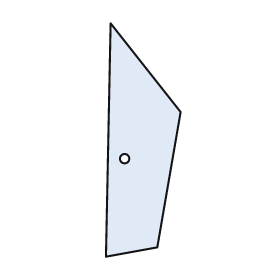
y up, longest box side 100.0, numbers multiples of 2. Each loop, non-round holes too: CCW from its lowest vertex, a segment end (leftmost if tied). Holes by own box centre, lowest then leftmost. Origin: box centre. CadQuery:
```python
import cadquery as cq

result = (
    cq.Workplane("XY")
    .moveTo(-16.0, -50.0)
    .lineTo(6.0, -46.0)
    .lineTo(16.0, 12.0)
    .lineTo(-14.0, 50.0)
    .close()
    .moveTo(-8.0, -8.0)
    .circle(2.0)
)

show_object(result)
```